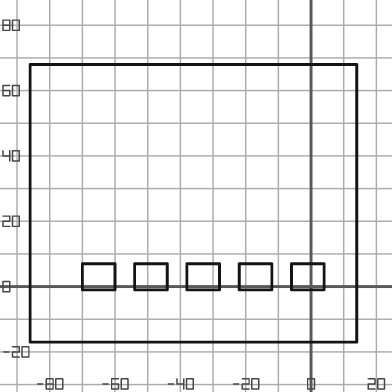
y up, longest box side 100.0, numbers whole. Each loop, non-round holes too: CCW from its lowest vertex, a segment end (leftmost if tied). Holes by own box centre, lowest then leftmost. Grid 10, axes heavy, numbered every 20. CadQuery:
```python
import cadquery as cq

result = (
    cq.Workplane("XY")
    .moveTo(-86.0, -17.0)
    .lineTo(14.0, -17.0)
    .lineTo(14.0, 68.0)
    .lineTo(-86.0, 68.0)
    .close()
    .moveTo(-70.0, -1.0)
    .lineTo(-60.0, -1.0)
    .lineTo(-60.0, 7.0)
    .lineTo(-70.0, 7.0)
    .close()
    .moveTo(-54.0, -1.0)
    .lineTo(-44.0, -1.0)
    .lineTo(-44.0, 7.0)
    .lineTo(-54.0, 7.0)
    .close()
    .moveTo(-38.0, -1.0)
    .lineTo(-28.0, -1.0)
    .lineTo(-28.0, 7.0)
    .lineTo(-38.0, 7.0)
    .close()
    .moveTo(-22.0, -1.0)
    .lineTo(-12.0, -1.0)
    .lineTo(-12.0, 7.0)
    .lineTo(-22.0, 7.0)
    .close()
    .moveTo(-6.0, -1.0)
    .lineTo(4.0, -1.0)
    .lineTo(4.0, 7.0)
    .lineTo(-6.0, 7.0)
    .close()
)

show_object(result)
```